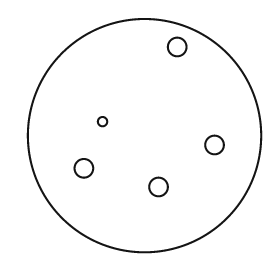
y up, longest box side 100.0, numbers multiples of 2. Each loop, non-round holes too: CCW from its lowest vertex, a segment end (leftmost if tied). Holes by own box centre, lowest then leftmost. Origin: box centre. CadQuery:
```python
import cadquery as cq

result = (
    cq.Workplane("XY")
    .moveTo(0.0, 0.0)
    .circle(50.0)
    .moveTo(6.0, -22.0)
    .circle(4.0)
    .moveTo(-26.0, -14.0)
    .circle(4.0)
    .moveTo(30.0, -4.0)
    .circle(4.0)
    .moveTo(-18.0, 6.0)
    .circle(2.0)
    .moveTo(14.0, 38.0)
    .circle(4.0)
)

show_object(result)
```